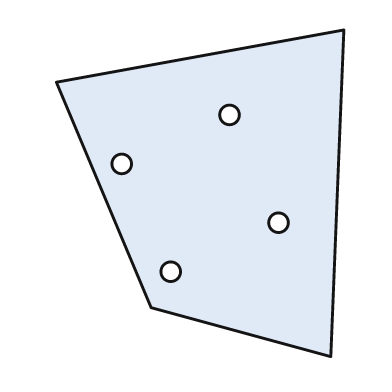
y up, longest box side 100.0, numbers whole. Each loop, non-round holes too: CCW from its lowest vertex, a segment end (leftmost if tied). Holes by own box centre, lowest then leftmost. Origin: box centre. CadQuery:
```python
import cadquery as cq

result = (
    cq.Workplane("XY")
    .moveTo(40.0, -50.0)
    .lineTo(44.0, 50.0)
    .lineTo(-44.0, 34.0)
    .lineTo(-15.0, -35.0)
    .close()
    .moveTo(-9.0, -24.0)
    .circle(3.0)
    .moveTo(24.0, -9.0)
    .circle(3.0)
    .moveTo(-24.0, 9.0)
    .circle(3.0)
    .moveTo(9.0, 24.0)
    .circle(3.0)
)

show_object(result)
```